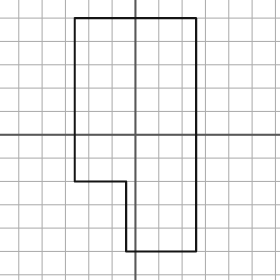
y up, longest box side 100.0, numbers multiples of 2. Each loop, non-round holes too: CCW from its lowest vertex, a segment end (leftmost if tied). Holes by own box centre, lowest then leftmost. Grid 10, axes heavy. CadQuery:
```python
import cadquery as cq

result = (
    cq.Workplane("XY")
    .moveTo(-4.0, -50.0)
    .lineTo(26.0, -50.0)
    .lineTo(26.0, 50.0)
    .lineTo(-26.0, 50.0)
    .lineTo(-26.0, -20.0)
    .lineTo(-4.0, -20.0)
    .close()
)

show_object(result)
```